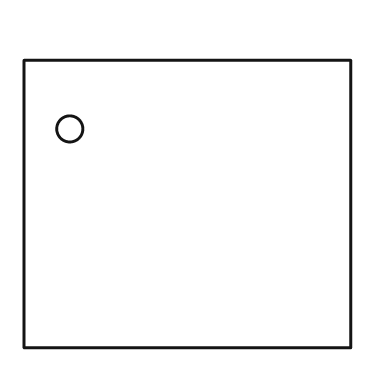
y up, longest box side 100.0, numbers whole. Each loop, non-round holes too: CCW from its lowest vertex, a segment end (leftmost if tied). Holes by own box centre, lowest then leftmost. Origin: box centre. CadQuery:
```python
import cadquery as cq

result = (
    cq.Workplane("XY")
    .moveTo(-50.0, -44.0)
    .lineTo(50.0, -44.0)
    .lineTo(50.0, 44.0)
    .lineTo(-50.0, 44.0)
    .close()
    .moveTo(-36.0, 23.0)
    .circle(4.0)
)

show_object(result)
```